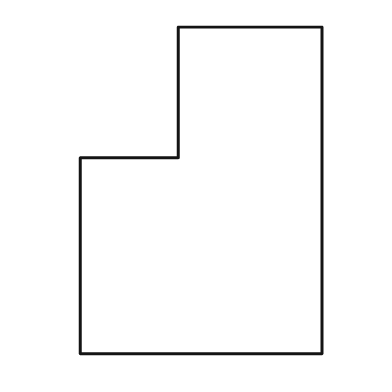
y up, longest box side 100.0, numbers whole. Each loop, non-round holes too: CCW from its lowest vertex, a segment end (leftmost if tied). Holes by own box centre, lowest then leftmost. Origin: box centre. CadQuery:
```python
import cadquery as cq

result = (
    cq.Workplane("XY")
    .moveTo(-37.0, -50.0)
    .lineTo(37.0, -50.0)
    .lineTo(37.0, 50.0)
    .lineTo(-7.0, 50.0)
    .lineTo(-7.0, 10.0)
    .lineTo(-37.0, 10.0)
    .close()
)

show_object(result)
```